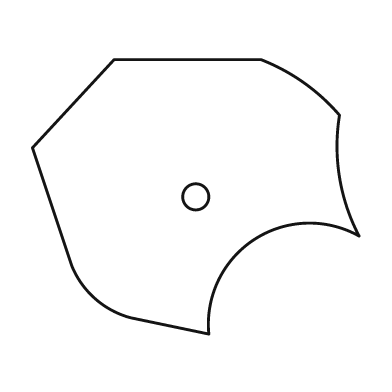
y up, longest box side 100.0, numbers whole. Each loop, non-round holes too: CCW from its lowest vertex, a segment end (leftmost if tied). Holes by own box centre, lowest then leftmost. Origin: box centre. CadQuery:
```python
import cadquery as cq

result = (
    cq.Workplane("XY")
    .moveTo(4.0, -42.0)
    .threePointArc((18.0, -13.0), (50.0, -12.0))
    .threePointArc((44.0, 6.0), (44.0, 25.0))
    .threePointArc((33.0, 35.0), (20.0, 42.0))
    .lineTo(-25.0, 42.0)
    .lineTo(-50.0, 15.0)
    .lineTo(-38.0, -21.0)
    .threePointArc((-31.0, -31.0), (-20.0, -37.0))
    .close()
    .moveTo(0.0, 0.0)
    .circle(4.0)
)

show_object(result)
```